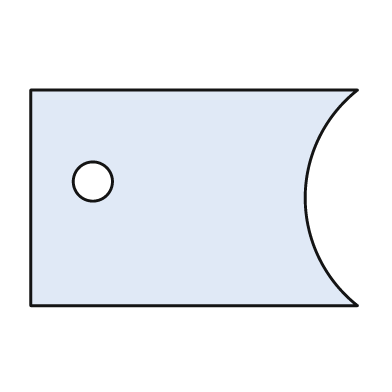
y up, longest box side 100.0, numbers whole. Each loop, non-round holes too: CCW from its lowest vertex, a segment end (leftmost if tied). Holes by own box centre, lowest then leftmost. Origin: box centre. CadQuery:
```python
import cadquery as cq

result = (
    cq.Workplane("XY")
    .moveTo(-50.0, -33.0)
    .lineTo(50.0, -33.0)
    .threePointArc((34.0, 0.0), (50.0, 33.0))
    .lineTo(-50.0, 33.0)
    .close()
    .moveTo(-31.0, 5.0)
    .circle(6.0)
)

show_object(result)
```